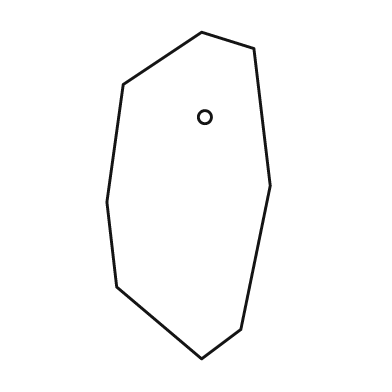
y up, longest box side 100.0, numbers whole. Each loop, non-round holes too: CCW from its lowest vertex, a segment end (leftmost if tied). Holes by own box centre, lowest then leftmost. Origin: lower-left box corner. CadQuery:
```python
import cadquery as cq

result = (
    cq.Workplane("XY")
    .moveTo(29.0, 0.0)
    .lineTo(41.0, 9.0)
    .lineTo(50.0, 53.0)
    .lineTo(45.0, 95.0)
    .lineTo(29.0, 100.0)
    .lineTo(5.0, 84.0)
    .lineTo(0.0, 48.0)
    .lineTo(3.0, 22.0)
    .close()
    .moveTo(30.0, 74.0)
    .circle(2.0)
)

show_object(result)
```